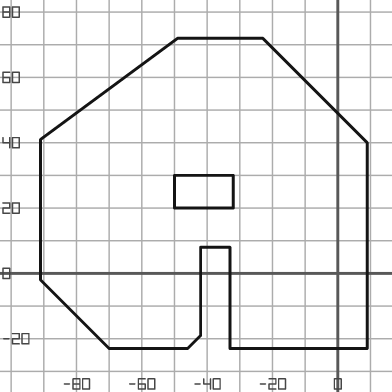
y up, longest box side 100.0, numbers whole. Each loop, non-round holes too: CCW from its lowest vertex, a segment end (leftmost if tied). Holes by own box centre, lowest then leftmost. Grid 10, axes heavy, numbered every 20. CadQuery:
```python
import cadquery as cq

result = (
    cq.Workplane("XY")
    .moveTo(-70.0, -23.0)
    .lineTo(-46.0, -23.0)
    .lineTo(-42.0, -19.0)
    .lineTo(-42.0, 8.0)
    .lineTo(-33.0, 8.0)
    .lineTo(-33.0, -23.0)
    .lineTo(9.0, -23.0)
    .lineTo(9.0, 40.0)
    .lineTo(-23.0, 72.0)
    .lineTo(-49.0, 72.0)
    .lineTo(-91.0, 41.0)
    .lineTo(-91.0, -2.0)
    .close()
    .moveTo(-50.0, 20.0)
    .lineTo(-32.0, 20.0)
    .lineTo(-32.0, 30.0)
    .lineTo(-50.0, 30.0)
    .close()
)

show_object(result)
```